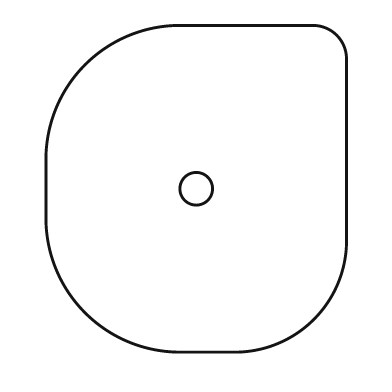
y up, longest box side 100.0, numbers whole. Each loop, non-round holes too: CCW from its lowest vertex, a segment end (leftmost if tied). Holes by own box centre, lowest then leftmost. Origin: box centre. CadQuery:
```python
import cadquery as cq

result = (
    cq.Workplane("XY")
    .moveTo(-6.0, -50.0)
    .lineTo(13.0, -50.0)
    .threePointArc((36.0, -40.0), (46.0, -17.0))
    .lineTo(46.0, 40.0)
    .threePointArc((43.0, 47.0), (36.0, 50.0))
    .lineTo(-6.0, 50.0)
    .threePointArc((-34.0, 38.0), (-46.0, 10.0))
    .lineTo(-46.0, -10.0)
    .threePointArc((-34.0, -38.0), (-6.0, -50.0))
    .close()
    .moveTo(0.0, 0.0)
    .circle(5.0)
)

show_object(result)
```